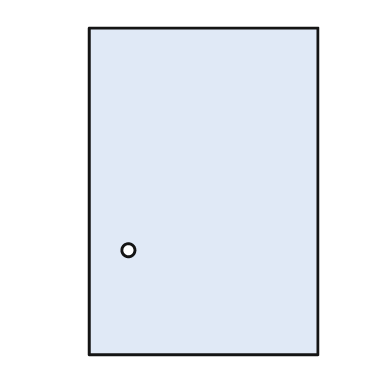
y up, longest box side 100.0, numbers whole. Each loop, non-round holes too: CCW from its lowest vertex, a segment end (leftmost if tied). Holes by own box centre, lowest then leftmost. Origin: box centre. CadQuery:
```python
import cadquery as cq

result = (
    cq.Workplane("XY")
    .moveTo(-35.0, -50.0)
    .lineTo(35.0, -50.0)
    .lineTo(35.0, 50.0)
    .lineTo(-35.0, 50.0)
    .close()
    .moveTo(-23.0, -18.0)
    .circle(2.0)
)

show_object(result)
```